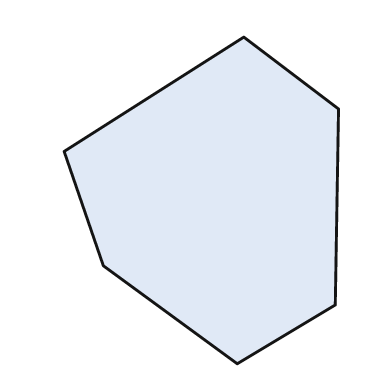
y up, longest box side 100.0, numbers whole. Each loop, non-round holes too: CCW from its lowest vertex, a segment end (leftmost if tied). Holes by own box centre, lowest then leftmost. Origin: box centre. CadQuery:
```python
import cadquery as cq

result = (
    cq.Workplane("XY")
    .moveTo(11.0, -50.0)
    .lineTo(41.0, -32.0)
    .lineTo(42.0, 28.0)
    .lineTo(13.0, 50.0)
    .lineTo(-42.0, 15.0)
    .lineTo(-30.0, -20.0)
    .close()
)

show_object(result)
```